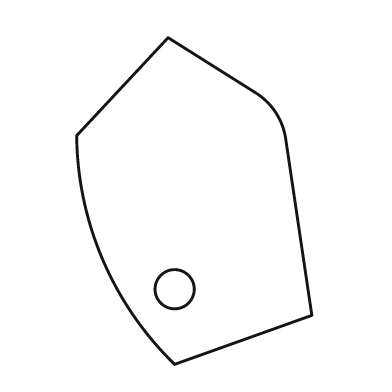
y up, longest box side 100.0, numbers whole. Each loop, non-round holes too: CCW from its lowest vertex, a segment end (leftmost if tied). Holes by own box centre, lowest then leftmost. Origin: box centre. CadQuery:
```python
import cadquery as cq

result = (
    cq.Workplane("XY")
    .moveTo(-6.0, -50.0)
    .lineTo(36.0, -35.0)
    .lineTo(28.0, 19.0)
    .threePointArc((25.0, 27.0), (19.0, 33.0))
    .lineTo(-8.0, 50.0)
    .lineTo(-36.0, 20.0)
    .threePointArc((-28.0, -18.0), (-6.0, -50.0))
    .close()
    .moveTo(-6.0, -27.0)
    .circle(6.0)
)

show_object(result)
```